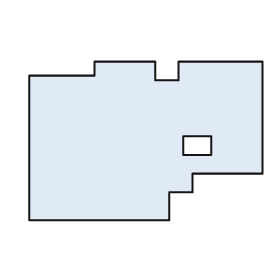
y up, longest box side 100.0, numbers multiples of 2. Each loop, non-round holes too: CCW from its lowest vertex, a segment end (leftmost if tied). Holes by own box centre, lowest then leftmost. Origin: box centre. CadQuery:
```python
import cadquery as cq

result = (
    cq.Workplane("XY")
    .moveTo(-50.0, -34.0)
    .lineTo(10.0, -34.0)
    .lineTo(10.0, -22.0)
    .lineTo(20.0, -22.0)
    .lineTo(20.0, -14.0)
    .lineTo(50.0, -14.0)
    .lineTo(50.0, 34.0)
    .lineTo(14.0, 34.0)
    .lineTo(14.0, 26.0)
    .lineTo(4.0, 26.0)
    .lineTo(4.0, 34.0)
    .lineTo(-22.0, 34.0)
    .lineTo(-22.0, 28.0)
    .lineTo(-50.0, 28.0)
    .close()
    .moveTo(16.0, -6.0)
    .lineTo(28.0, -6.0)
    .lineTo(28.0, 2.0)
    .lineTo(16.0, 2.0)
    .close()
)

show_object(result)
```